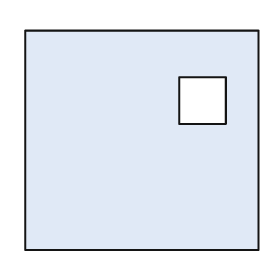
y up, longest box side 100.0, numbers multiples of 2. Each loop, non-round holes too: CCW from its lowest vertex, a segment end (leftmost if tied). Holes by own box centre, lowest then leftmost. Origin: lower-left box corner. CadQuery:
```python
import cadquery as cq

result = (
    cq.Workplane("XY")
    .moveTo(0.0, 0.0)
    .lineTo(100.0, 0.0)
    .lineTo(100.0, 94.0)
    .lineTo(0.0, 94.0)
    .close()
    .moveTo(66.0, 54.0)
    .lineTo(86.0, 54.0)
    .lineTo(86.0, 74.0)
    .lineTo(66.0, 74.0)
    .close()
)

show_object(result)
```